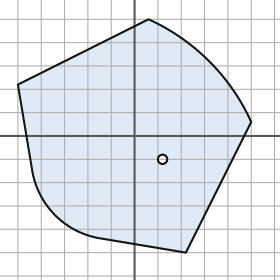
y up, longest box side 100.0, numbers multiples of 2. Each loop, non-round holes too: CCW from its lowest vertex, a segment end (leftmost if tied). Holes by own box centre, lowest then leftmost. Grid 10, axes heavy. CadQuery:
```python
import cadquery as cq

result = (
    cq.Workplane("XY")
    .moveTo(22.0, -50.0)
    .lineTo(50.0, 6.0)
    .threePointArc((32.0, 32.0), (6.0, 50.0))
    .lineTo(-50.0, 22.0)
    .lineTo(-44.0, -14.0)
    .threePointArc((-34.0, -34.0), (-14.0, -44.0))
    .close()
    .moveTo(12.0, -10.0)
    .circle(2.0)
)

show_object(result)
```